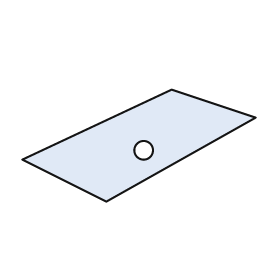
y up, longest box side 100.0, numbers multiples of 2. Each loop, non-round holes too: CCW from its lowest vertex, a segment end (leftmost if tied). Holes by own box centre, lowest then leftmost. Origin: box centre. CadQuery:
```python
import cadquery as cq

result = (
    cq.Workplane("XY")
    .moveTo(-14.0, -24.0)
    .lineTo(50.0, 12.0)
    .lineTo(14.0, 24.0)
    .lineTo(-50.0, -6.0)
    .close()
    .moveTo(2.0, -2.0)
    .circle(4.0)
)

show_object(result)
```